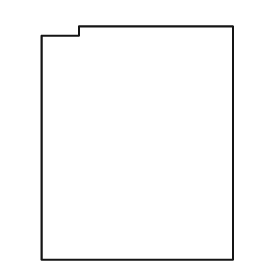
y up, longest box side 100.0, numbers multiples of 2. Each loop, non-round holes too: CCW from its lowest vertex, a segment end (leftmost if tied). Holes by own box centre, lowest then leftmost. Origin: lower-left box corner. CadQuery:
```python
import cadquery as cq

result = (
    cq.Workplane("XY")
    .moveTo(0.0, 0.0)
    .lineTo(82.0, 0.0)
    .lineTo(82.0, 100.0)
    .lineTo(16.0, 100.0)
    .lineTo(16.0, 96.0)
    .lineTo(0.0, 96.0)
    .close()
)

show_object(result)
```